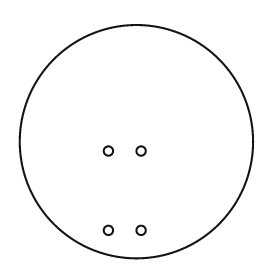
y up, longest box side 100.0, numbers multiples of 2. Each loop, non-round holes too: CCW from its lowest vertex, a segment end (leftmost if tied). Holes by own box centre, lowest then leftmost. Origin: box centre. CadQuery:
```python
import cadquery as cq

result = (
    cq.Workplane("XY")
    .moveTo(0.0, 0.0)
    .circle(50.0)
    .moveTo(-12.0, -38.0)
    .circle(2.0)
    .moveTo(2.0, -38.0)
    .circle(2.0)
    .moveTo(-12.0, -4.0)
    .circle(2.0)
    .moveTo(2.0, -4.0)
    .circle(2.0)
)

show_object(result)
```